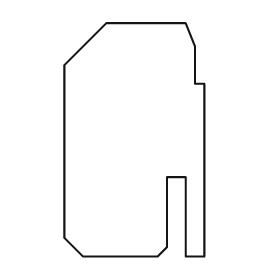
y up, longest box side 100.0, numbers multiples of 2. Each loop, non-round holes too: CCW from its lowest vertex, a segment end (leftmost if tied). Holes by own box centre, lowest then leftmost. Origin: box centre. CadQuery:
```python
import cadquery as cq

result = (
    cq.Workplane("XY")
    .moveTo(-22.0, -50.0)
    .lineTo(10.0, -50.0)
    .lineTo(14.0, -46.0)
    .lineTo(14.0, -16.0)
    .lineTo(22.0, -16.0)
    .lineTo(22.0, -50.0)
    .lineTo(30.0, -50.0)
    .lineTo(30.0, 24.0)
    .lineTo(26.0, 24.0)
    .lineTo(26.0, 40.0)
    .lineTo(22.0, 50.0)
    .lineTo(-12.0, 50.0)
    .lineTo(-30.0, 32.0)
    .lineTo(-30.0, -42.0)
    .close()
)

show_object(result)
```